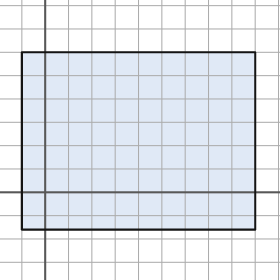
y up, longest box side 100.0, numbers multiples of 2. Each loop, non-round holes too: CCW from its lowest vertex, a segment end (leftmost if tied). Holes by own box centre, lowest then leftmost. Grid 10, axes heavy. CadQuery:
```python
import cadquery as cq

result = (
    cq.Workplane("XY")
    .moveTo(-10.0, -16.0)
    .lineTo(90.0, -16.0)
    .lineTo(90.0, 60.0)
    .lineTo(-10.0, 60.0)
    .close()
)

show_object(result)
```